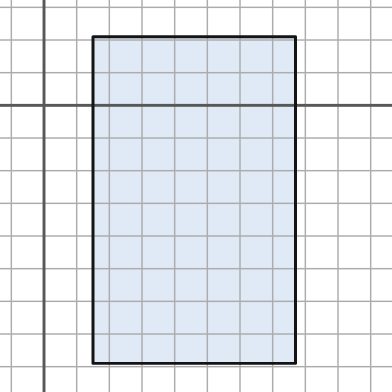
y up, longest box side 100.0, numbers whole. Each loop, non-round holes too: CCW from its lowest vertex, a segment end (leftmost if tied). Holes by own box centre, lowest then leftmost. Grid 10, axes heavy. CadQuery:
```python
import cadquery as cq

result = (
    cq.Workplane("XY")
    .moveTo(15.0, -79.0)
    .lineTo(77.0, -79.0)
    .lineTo(77.0, 21.0)
    .lineTo(15.0, 21.0)
    .close()
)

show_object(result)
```